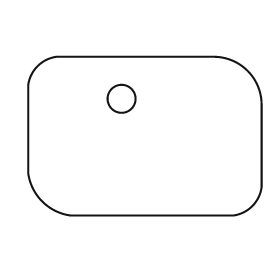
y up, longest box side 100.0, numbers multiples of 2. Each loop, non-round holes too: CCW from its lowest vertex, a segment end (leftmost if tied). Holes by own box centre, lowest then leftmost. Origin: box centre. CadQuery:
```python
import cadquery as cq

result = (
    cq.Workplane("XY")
    .moveTo(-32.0, -34.0)
    .lineTo(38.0, -34.0)
    .threePointArc((46.0, -30.0), (50.0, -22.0))
    .lineTo(50.0, 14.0)
    .threePointArc((44.0, 28.0), (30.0, 34.0))
    .lineTo(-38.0, 34.0)
    .threePointArc((-46.0, 30.0), (-50.0, 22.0))
    .lineTo(-50.0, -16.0)
    .threePointArc((-44.0, -28.0), (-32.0, -34.0))
    .close()
    .moveTo(-10.0, 16.0)
    .circle(6.0)
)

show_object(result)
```